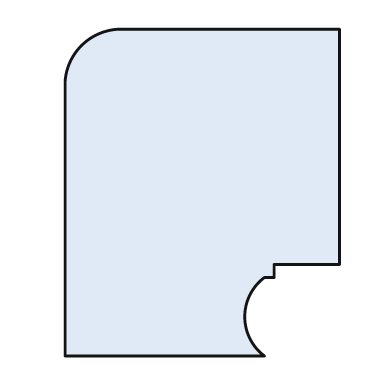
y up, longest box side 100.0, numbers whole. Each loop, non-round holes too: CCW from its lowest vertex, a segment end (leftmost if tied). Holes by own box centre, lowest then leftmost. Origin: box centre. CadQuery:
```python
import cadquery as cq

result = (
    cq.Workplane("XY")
    .moveTo(-42.0, -50.0)
    .lineTo(19.0, -50.0)
    .threePointArc((13.0, -38.0), (19.0, -26.0))
    .lineTo(22.0, -26.0)
    .lineTo(22.0, -22.0)
    .lineTo(42.0, -22.0)
    .lineTo(42.0, 50.0)
    .lineTo(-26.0, 50.0)
    .threePointArc((-37.0, 45.0), (-42.0, 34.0))
    .close()
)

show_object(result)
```